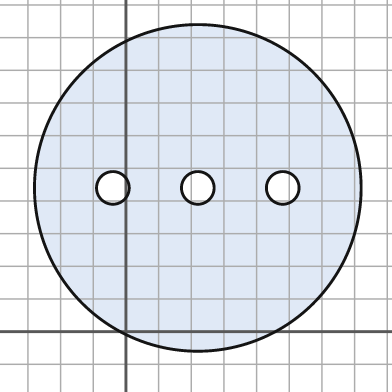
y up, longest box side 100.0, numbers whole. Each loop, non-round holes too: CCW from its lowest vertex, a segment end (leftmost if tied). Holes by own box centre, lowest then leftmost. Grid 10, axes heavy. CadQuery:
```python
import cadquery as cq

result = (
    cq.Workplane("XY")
    .moveTo(22.0, 44.0)
    .circle(50.0)
    .moveTo(-4.0, 44.0)
    .circle(5.0)
    .moveTo(22.0, 44.0)
    .circle(5.0)
    .moveTo(48.0, 44.0)
    .circle(5.0)
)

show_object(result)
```